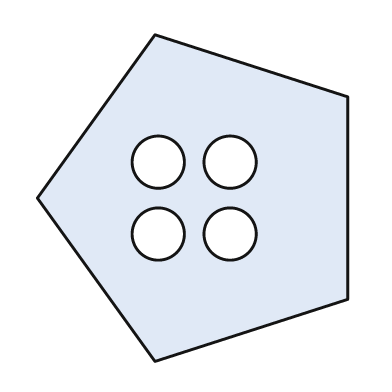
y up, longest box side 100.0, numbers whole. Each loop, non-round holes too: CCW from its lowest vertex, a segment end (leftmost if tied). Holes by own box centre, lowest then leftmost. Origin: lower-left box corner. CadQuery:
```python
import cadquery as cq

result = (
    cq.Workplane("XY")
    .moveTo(36.0, 0.0)
    .lineTo(95.0, 19.0)
    .lineTo(95.0, 81.0)
    .lineTo(36.0, 100.0)
    .lineTo(0.0, 50.0)
    .close()
    .moveTo(37.0, 39.0)
    .circle(8.0)
    .moveTo(59.0, 39.0)
    .circle(8.0)
    .moveTo(37.0, 61.0)
    .circle(8.0)
    .moveTo(59.0, 61.0)
    .circle(8.0)
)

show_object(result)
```